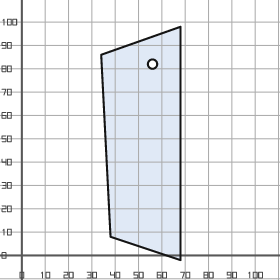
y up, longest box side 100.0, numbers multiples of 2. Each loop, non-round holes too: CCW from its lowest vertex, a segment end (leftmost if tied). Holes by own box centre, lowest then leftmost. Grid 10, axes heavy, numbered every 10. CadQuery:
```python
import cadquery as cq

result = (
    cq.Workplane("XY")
    .moveTo(68.0, -2.0)
    .lineTo(68.0, 98.0)
    .lineTo(34.0, 86.0)
    .lineTo(38.0, 8.0)
    .close()
    .moveTo(56.0, 82.0)
    .circle(2.0)
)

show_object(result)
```